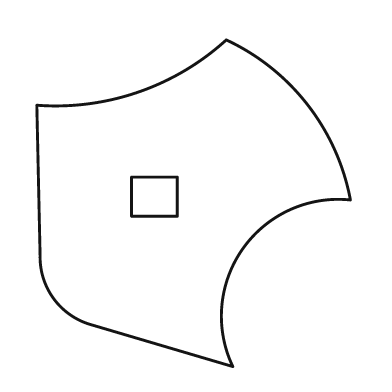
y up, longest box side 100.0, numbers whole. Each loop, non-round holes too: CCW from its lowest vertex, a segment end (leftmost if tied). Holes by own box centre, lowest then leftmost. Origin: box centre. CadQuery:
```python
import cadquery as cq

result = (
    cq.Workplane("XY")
    .moveTo(12.0, -50.0)
    .threePointArc((15.0, -14.0), (48.0, 1.0))
    .threePointArc((35.0, 30.0), (10.0, 50.0))
    .threePointArc((-17.0, 34.0), (-48.0, 30.0))
    .lineTo(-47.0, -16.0)
    .threePointArc((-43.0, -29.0), (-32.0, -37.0))
    .close()
    .moveTo(-19.0, -4.0)
    .lineTo(-5.0, -4.0)
    .lineTo(-5.0, 8.0)
    .lineTo(-19.0, 8.0)
    .close()
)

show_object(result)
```